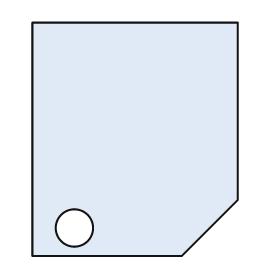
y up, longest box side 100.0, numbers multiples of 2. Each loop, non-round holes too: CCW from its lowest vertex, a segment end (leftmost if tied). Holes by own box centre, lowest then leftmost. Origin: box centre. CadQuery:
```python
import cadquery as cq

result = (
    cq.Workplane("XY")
    .moveTo(-44.0, -50.0)
    .lineTo(20.0, -50.0)
    .lineTo(44.0, -26.0)
    .lineTo(44.0, 50.0)
    .lineTo(-44.0, 50.0)
    .close()
    .moveTo(-26.0, -38.0)
    .circle(8.0)
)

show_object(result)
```